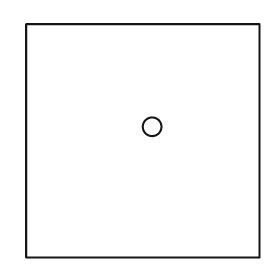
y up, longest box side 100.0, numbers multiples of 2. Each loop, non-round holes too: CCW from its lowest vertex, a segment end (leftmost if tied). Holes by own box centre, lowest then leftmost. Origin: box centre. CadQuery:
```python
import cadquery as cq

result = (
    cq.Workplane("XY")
    .moveTo(-50.0, -50.0)
    .lineTo(50.0, -50.0)
    .lineTo(50.0, 50.0)
    .lineTo(-50.0, 50.0)
    .close()
    .moveTo(4.0, 6.0)
    .circle(4.0)
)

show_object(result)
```